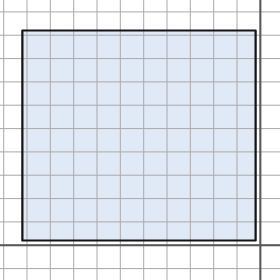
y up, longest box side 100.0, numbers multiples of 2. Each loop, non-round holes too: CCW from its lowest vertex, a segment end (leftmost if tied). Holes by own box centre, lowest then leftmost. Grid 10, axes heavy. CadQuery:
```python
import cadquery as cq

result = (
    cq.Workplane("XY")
    .moveTo(-102.0, 2.0)
    .lineTo(-2.0, 2.0)
    .lineTo(-2.0, 92.0)
    .lineTo(-102.0, 92.0)
    .close()
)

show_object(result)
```